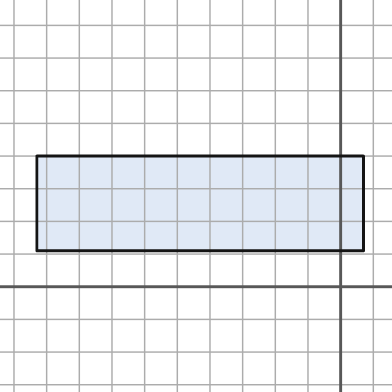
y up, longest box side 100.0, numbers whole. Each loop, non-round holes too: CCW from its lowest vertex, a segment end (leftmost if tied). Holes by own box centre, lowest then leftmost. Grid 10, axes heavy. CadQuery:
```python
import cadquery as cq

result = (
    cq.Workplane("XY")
    .moveTo(-93.0, 11.0)
    .lineTo(7.0, 11.0)
    .lineTo(7.0, 40.0)
    .lineTo(-93.0, 40.0)
    .close()
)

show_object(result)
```